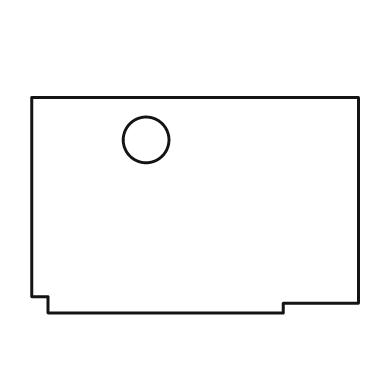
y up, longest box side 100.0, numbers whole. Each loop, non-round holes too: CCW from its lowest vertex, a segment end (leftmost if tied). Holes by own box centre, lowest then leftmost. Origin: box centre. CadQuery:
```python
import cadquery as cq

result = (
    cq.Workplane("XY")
    .moveTo(-45.0, -33.0)
    .lineTo(27.0, -33.0)
    .lineTo(27.0, -30.0)
    .lineTo(50.0, -30.0)
    .lineTo(50.0, 33.0)
    .lineTo(-50.0, 33.0)
    .lineTo(-50.0, -28.0)
    .lineTo(-45.0, -28.0)
    .close()
    .moveTo(-15.0, 20.0)
    .circle(7.0)
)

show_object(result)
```